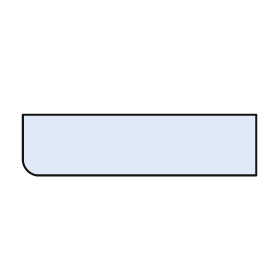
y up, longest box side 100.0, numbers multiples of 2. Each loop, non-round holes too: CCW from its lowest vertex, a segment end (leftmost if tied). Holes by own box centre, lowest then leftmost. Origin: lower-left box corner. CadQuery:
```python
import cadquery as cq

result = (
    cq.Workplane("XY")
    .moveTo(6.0, 0.0)
    .lineTo(100.0, 0.0)
    .lineTo(100.0, 26.0)
    .lineTo(0.0, 26.0)
    .lineTo(0.0, 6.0)
    .threePointArc((2.0, 2.0), (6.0, 0.0))
    .close()
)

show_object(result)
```